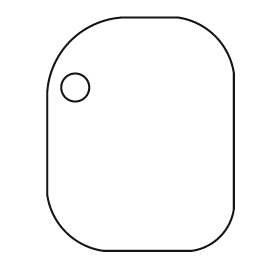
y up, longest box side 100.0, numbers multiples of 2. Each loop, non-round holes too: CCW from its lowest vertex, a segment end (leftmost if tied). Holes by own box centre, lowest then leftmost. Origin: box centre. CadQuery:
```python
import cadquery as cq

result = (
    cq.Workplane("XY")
    .moveTo(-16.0, -50.0)
    .lineTo(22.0, -50.0)
    .threePointArc((34.0, -44.0), (40.0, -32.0))
    .lineTo(40.0, 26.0)
    .threePointArc((32.0, 42.0), (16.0, 50.0))
    .lineTo(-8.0, 50.0)
    .threePointArc((-30.0, 40.0), (-40.0, 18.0))
    .lineTo(-40.0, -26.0)
    .threePointArc((-32.0, -42.0), (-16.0, -50.0))
    .close()
    .moveTo(-28.0, 20.0)
    .circle(6.0)
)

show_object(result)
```